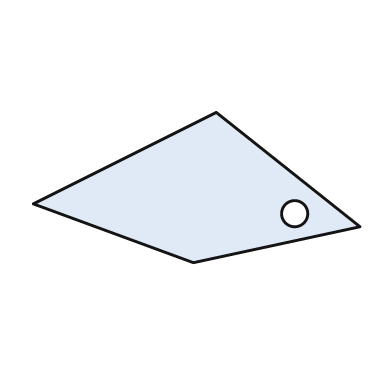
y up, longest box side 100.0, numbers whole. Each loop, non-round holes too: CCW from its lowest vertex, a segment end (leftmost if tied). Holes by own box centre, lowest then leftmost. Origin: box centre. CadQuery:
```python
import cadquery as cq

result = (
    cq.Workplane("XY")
    .moveTo(-1.0, -23.0)
    .lineTo(50.0, -12.0)
    .lineTo(6.0, 23.0)
    .lineTo(-50.0, -5.0)
    .close()
    .moveTo(30.0, -8.0)
    .circle(4.0)
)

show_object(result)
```